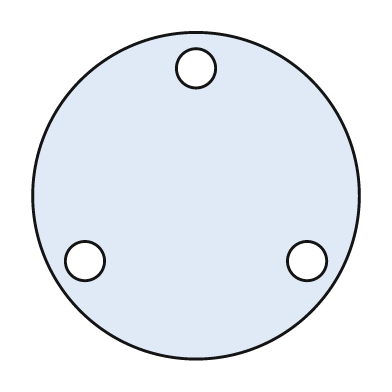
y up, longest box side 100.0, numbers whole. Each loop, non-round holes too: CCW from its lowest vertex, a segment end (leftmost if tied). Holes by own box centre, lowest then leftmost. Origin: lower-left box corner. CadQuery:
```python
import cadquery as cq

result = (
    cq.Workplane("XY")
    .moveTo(50.0, 50.0)
    .circle(50.0)
    .moveTo(16.0, 30.0)
    .circle(6.0)
    .moveTo(84.0, 30.0)
    .circle(6.0)
    .moveTo(50.0, 89.0)
    .circle(6.0)
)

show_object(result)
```